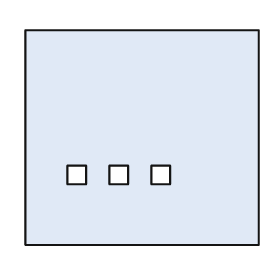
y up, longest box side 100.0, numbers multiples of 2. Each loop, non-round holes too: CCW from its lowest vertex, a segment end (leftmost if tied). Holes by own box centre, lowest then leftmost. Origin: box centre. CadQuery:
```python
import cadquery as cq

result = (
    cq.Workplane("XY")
    .moveTo(-50.0, -46.0)
    .lineTo(50.0, -46.0)
    .lineTo(50.0, 46.0)
    .lineTo(-50.0, 46.0)
    .close()
    .moveTo(-32.0, -20.0)
    .lineTo(-24.0, -20.0)
    .lineTo(-24.0, -12.0)
    .lineTo(-32.0, -12.0)
    .close()
    .moveTo(-14.0, -20.0)
    .lineTo(-6.0, -20.0)
    .lineTo(-6.0, -12.0)
    .lineTo(-14.0, -12.0)
    .close()
    .moveTo(4.0, -20.0)
    .lineTo(12.0, -20.0)
    .lineTo(12.0, -12.0)
    .lineTo(4.0, -12.0)
    .close()
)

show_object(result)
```